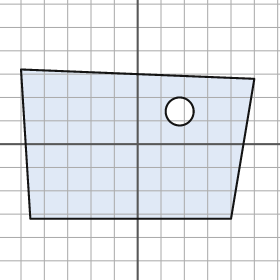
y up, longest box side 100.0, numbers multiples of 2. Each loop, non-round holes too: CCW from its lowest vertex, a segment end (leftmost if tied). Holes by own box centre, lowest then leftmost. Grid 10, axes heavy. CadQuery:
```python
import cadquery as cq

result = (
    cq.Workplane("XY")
    .moveTo(-46.0, -32.0)
    .lineTo(40.0, -32.0)
    .lineTo(50.0, 28.0)
    .lineTo(-50.0, 32.0)
    .close()
    .moveTo(18.0, 14.0)
    .circle(6.0)
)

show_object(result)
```